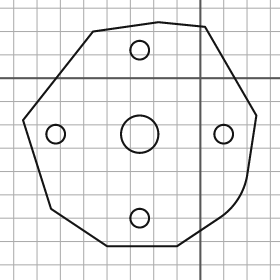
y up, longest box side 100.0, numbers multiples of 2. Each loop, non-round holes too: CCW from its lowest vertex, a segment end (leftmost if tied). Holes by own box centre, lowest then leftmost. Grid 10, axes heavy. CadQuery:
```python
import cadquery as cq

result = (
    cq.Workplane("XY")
    .moveTo(-40.0, -72.0)
    .lineTo(-10.0, -72.0)
    .lineTo(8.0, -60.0)
    .threePointArc((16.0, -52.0), (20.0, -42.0))
    .lineTo(24.0, -16.0)
    .lineTo(2.0, 22.0)
    .lineTo(-18.0, 24.0)
    .lineTo(-46.0, 20.0)
    .lineTo(-76.0, -18.0)
    .lineTo(-64.0, -56.0)
    .close()
    .moveTo(-26.0, -60.0)
    .circle(4.0)
    .moveTo(-62.0, -24.0)
    .circle(4.0)
    .moveTo(-26.0, -24.0)
    .circle(8.0)
    .moveTo(10.0, -24.0)
    .circle(4.0)
    .moveTo(-26.0, 12.0)
    .circle(4.0)
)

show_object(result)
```